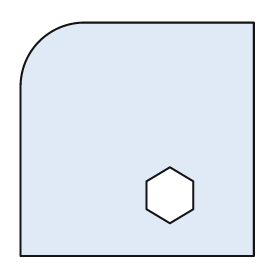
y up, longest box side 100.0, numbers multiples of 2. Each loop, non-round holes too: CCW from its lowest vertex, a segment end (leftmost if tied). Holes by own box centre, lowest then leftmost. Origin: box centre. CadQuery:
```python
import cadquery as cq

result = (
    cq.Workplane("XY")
    .moveTo(-50.0, -50.0)
    .lineTo(50.0, -50.0)
    .lineTo(50.0, 50.0)
    .lineTo(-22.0, 50.0)
    .threePointArc((-42.0, 42.0), (-50.0, 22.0))
    .close()
    .moveTo(14.0, -36.0)
    .lineTo(24.0, -30.0)
    .lineTo(24.0, -18.0)
    .lineTo(14.0, -12.0)
    .lineTo(4.0, -18.0)
    .lineTo(4.0, -30.0)
    .close()
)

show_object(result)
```